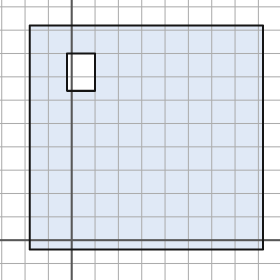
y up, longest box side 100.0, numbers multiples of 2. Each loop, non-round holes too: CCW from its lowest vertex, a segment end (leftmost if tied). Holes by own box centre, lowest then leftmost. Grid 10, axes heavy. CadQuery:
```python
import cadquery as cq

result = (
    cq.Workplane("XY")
    .moveTo(-18.0, -4.0)
    .lineTo(82.0, -4.0)
    .lineTo(82.0, 92.0)
    .lineTo(-18.0, 92.0)
    .close()
    .moveTo(-2.0, 64.0)
    .lineTo(10.0, 64.0)
    .lineTo(10.0, 80.0)
    .lineTo(-2.0, 80.0)
    .close()
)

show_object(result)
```